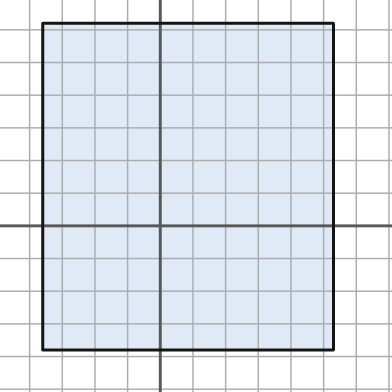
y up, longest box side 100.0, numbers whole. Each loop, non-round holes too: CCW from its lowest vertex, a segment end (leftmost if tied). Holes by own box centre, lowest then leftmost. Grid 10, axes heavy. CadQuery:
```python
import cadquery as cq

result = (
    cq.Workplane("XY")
    .moveTo(-36.0, -38.0)
    .lineTo(53.0, -38.0)
    .lineTo(53.0, 62.0)
    .lineTo(-36.0, 62.0)
    .close()
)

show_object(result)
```